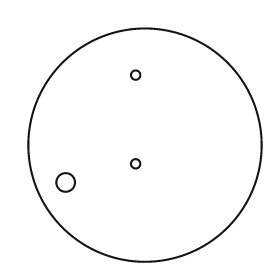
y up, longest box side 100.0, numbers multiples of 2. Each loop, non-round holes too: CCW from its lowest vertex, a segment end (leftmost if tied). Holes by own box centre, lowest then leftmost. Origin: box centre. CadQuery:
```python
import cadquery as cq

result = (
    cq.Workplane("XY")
    .moveTo(0.0, 0.0)
    .circle(50.0)
    .moveTo(-34.0, -16.0)
    .circle(4.0)
    .moveTo(-4.0, -8.0)
    .circle(2.0)
    .moveTo(-4.0, 30.0)
    .circle(2.0)
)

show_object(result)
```